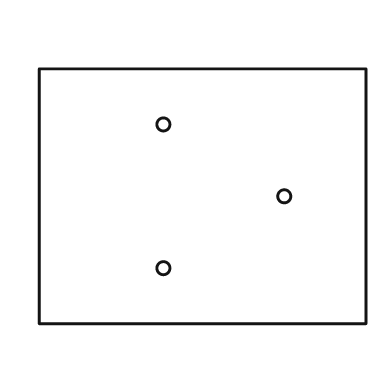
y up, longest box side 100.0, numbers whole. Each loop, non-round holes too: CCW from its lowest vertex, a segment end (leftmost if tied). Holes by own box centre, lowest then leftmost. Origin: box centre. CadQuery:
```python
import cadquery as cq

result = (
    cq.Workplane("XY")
    .moveTo(-50.0, -39.0)
    .lineTo(50.0, -39.0)
    .lineTo(50.0, 39.0)
    .lineTo(-50.0, 39.0)
    .close()
    .moveTo(-12.0, -22.0)
    .circle(2.0)
    .moveTo(25.0, 0.0)
    .circle(2.0)
    .moveTo(-12.0, 22.0)
    .circle(2.0)
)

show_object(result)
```